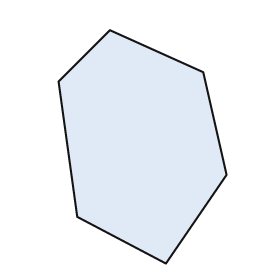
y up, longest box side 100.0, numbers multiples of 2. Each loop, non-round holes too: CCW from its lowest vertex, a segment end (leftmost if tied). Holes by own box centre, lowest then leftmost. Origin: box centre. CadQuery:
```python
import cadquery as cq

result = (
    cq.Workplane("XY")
    .moveTo(10.0, -50.0)
    .lineTo(36.0, -12.0)
    .lineTo(26.0, 32.0)
    .lineTo(-14.0, 50.0)
    .lineTo(-36.0, 28.0)
    .lineTo(-28.0, -30.0)
    .close()
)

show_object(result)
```